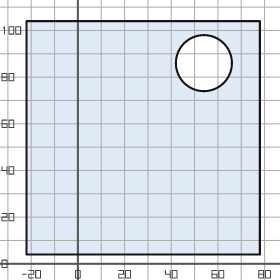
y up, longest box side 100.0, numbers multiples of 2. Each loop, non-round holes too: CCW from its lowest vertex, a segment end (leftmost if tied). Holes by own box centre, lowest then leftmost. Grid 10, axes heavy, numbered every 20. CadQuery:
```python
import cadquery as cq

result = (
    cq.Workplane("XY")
    .moveTo(-22.0, 4.0)
    .lineTo(78.0, 4.0)
    .lineTo(78.0, 104.0)
    .lineTo(-22.0, 104.0)
    .close()
    .moveTo(54.0, 86.0)
    .circle(12.0)
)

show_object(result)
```